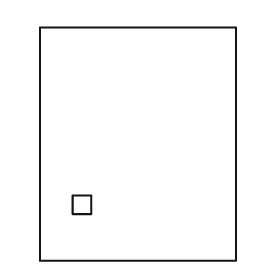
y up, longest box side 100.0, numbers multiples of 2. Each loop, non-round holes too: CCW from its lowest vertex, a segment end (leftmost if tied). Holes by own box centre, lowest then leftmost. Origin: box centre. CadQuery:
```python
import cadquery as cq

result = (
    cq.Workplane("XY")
    .moveTo(-42.0, -50.0)
    .lineTo(42.0, -50.0)
    .lineTo(42.0, 50.0)
    .lineTo(-42.0, 50.0)
    .close()
    .moveTo(-28.0, -30.0)
    .lineTo(-20.0, -30.0)
    .lineTo(-20.0, -22.0)
    .lineTo(-28.0, -22.0)
    .close()
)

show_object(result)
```